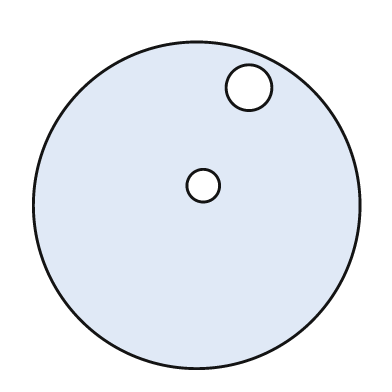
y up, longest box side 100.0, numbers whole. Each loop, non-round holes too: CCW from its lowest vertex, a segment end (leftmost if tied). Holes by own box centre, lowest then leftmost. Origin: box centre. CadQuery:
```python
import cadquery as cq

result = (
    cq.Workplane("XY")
    .moveTo(0.0, 0.0)
    .circle(50.0)
    .moveTo(2.0, 6.0)
    .circle(5.0)
    .moveTo(16.0, 36.0)
    .circle(7.0)
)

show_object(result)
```